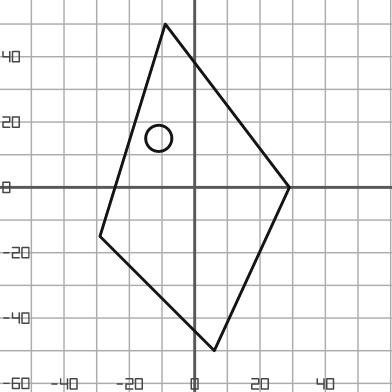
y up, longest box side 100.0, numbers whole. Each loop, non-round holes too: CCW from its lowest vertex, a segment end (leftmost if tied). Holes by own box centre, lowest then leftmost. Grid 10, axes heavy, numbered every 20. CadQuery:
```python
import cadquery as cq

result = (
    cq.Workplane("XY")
    .moveTo(6.0, -50.0)
    .lineTo(29.0, 0.0)
    .lineTo(-9.0, 50.0)
    .lineTo(-29.0, -15.0)
    .close()
    .moveTo(-11.0, 15.0)
    .circle(4.0)
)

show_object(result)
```